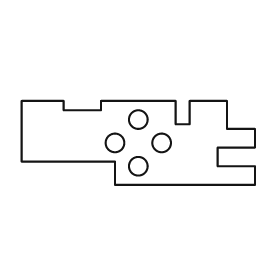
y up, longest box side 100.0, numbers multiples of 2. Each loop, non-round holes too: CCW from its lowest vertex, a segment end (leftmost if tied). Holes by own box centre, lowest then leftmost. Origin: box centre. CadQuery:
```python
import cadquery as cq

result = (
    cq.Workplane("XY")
    .moveTo(-10.0, -18.0)
    .lineTo(50.0, -18.0)
    .lineTo(50.0, -10.0)
    .lineTo(34.0, -10.0)
    .lineTo(34.0, -2.0)
    .lineTo(50.0, -2.0)
    .lineTo(50.0, 6.0)
    .lineTo(38.0, 6.0)
    .lineTo(38.0, 18.0)
    .lineTo(22.0, 18.0)
    .lineTo(22.0, 8.0)
    .lineTo(16.0, 8.0)
    .lineTo(16.0, 18.0)
    .lineTo(-16.0, 18.0)
    .lineTo(-16.0, 14.0)
    .lineTo(-32.0, 14.0)
    .lineTo(-32.0, 18.0)
    .lineTo(-50.0, 18.0)
    .lineTo(-50.0, -8.0)
    .lineTo(-10.0, -8.0)
    .close()
    .moveTo(0.0, -10.0)
    .circle(4.0)
    .moveTo(-10.0, 0.0)
    .circle(4.0)
    .moveTo(10.0, 0.0)
    .circle(4.0)
    .moveTo(0.0, 10.0)
    .circle(4.0)
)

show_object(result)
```